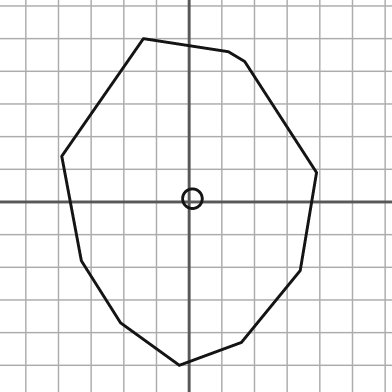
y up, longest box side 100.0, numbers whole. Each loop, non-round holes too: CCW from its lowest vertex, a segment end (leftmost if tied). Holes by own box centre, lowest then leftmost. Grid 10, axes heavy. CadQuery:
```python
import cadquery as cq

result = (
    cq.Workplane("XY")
    .moveTo(-3.0, -50.0)
    .lineTo(16.0, -43.0)
    .lineTo(34.0, -21.0)
    .lineTo(39.0, 9.0)
    .lineTo(17.0, 43.0)
    .lineTo(12.0, 46.0)
    .lineTo(-14.0, 50.0)
    .lineTo(-39.0, 14.0)
    .lineTo(-33.0, -18.0)
    .lineTo(-21.0, -37.0)
    .close()
    .moveTo(1.0, 1.0)
    .circle(3.0)
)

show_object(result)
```